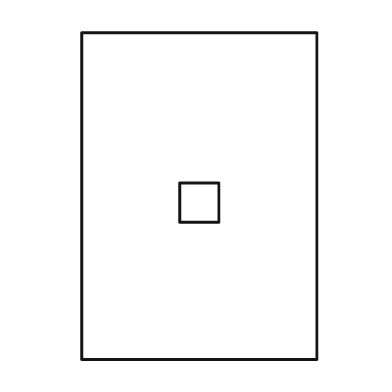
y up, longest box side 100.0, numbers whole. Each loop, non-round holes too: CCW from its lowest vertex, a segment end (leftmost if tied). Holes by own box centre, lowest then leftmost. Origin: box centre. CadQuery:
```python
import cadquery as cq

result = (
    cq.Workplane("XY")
    .moveTo(-36.0, -50.0)
    .lineTo(36.0, -50.0)
    .lineTo(36.0, 50.0)
    .lineTo(-36.0, 50.0)
    .close()
    .moveTo(-6.0, -8.0)
    .lineTo(6.0, -8.0)
    .lineTo(6.0, 4.0)
    .lineTo(-6.0, 4.0)
    .close()
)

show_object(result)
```